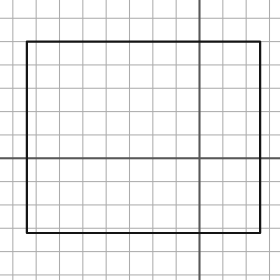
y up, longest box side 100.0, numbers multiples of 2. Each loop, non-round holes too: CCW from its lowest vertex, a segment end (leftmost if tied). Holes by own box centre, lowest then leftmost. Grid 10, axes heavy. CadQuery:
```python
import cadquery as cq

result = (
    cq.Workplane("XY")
    .moveTo(-74.0, -32.0)
    .lineTo(26.0, -32.0)
    .lineTo(26.0, 50.0)
    .lineTo(-74.0, 50.0)
    .close()
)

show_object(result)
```